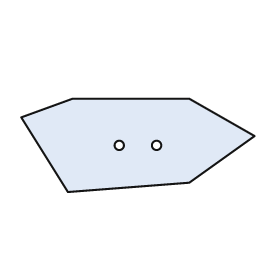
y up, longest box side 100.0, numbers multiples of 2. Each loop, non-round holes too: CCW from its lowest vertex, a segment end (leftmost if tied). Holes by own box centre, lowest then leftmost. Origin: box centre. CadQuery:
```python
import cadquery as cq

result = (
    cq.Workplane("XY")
    .moveTo(-30.0, -20.0)
    .lineTo(22.0, -16.0)
    .lineTo(50.0, 4.0)
    .lineTo(22.0, 20.0)
    .lineTo(-28.0, 20.0)
    .lineTo(-50.0, 12.0)
    .close()
    .moveTo(-8.0, 0.0)
    .circle(2.0)
    .moveTo(8.0, 0.0)
    .circle(2.0)
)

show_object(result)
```